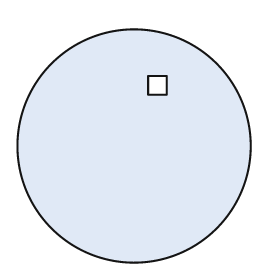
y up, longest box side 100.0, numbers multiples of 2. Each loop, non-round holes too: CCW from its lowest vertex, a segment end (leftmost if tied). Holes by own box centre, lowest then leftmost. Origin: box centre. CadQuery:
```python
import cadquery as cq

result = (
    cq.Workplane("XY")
    .moveTo(0.0, 0.0)
    .circle(50.0)
    .moveTo(6.0, 22.0)
    .lineTo(14.0, 22.0)
    .lineTo(14.0, 30.0)
    .lineTo(6.0, 30.0)
    .close()
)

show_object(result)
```